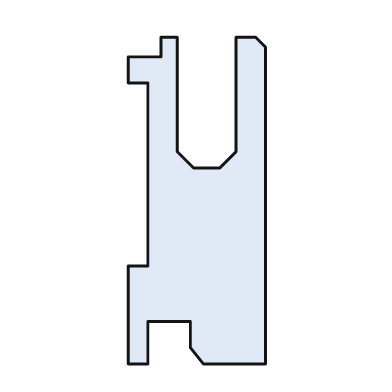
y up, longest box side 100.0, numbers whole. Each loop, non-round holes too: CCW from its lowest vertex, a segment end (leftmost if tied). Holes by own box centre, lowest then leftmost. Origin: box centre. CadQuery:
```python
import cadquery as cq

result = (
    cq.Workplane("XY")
    .moveTo(-21.0, -50.0)
    .lineTo(-15.0, -50.0)
    .lineTo(-15.0, -37.0)
    .lineTo(-2.0, -37.0)
    .lineTo(-2.0, -45.0)
    .lineTo(2.0, -50.0)
    .lineTo(21.0, -50.0)
    .lineTo(21.0, 47.0)
    .lineTo(18.0, 50.0)
    .lineTo(12.0, 50.0)
    .lineTo(12.0, 15.0)
    .lineTo(7.0, 10.0)
    .lineTo(-1.0, 10.0)
    .lineTo(-6.0, 15.0)
    .lineTo(-6.0, 50.0)
    .lineTo(-11.0, 50.0)
    .lineTo(-11.0, 44.0)
    .lineTo(-21.0, 44.0)
    .lineTo(-21.0, 36.0)
    .lineTo(-15.0, 36.0)
    .lineTo(-15.0, -20.0)
    .lineTo(-21.0, -20.0)
    .close()
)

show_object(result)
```